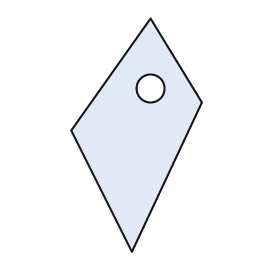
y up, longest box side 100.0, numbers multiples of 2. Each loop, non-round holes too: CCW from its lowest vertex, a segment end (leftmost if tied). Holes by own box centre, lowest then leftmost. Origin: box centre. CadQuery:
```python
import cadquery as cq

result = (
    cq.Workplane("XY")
    .moveTo(-2.0, -50.0)
    .lineTo(28.0, 14.0)
    .lineTo(6.0, 50.0)
    .lineTo(-28.0, 2.0)
    .close()
    .moveTo(6.0, 20.0)
    .circle(6.0)
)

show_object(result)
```